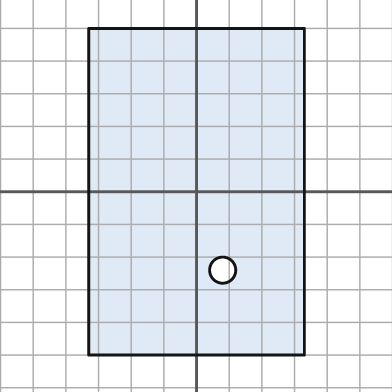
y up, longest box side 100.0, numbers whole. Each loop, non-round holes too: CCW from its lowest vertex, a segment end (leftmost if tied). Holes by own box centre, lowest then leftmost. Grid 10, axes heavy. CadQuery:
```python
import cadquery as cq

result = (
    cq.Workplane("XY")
    .moveTo(-33.0, -50.0)
    .lineTo(33.0, -50.0)
    .lineTo(33.0, 50.0)
    .lineTo(-33.0, 50.0)
    .close()
    .moveTo(8.0, -24.0)
    .circle(4.0)
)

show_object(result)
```